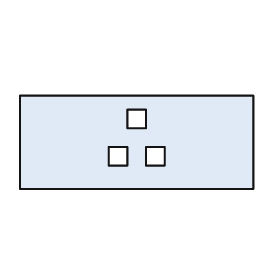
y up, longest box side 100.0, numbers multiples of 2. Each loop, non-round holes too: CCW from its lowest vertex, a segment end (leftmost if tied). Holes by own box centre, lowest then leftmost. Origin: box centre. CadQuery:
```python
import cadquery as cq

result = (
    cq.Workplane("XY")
    .moveTo(-50.0, -20.0)
    .lineTo(50.0, -20.0)
    .lineTo(50.0, 20.0)
    .lineTo(-50.0, 20.0)
    .close()
    .moveTo(-12.0, -10.0)
    .lineTo(-4.0, -10.0)
    .lineTo(-4.0, -2.0)
    .lineTo(-12.0, -2.0)
    .close()
    .moveTo(4.0, -10.0)
    .lineTo(12.0, -10.0)
    .lineTo(12.0, -2.0)
    .lineTo(4.0, -2.0)
    .close()
    .moveTo(-4.0, 6.0)
    .lineTo(4.0, 6.0)
    .lineTo(4.0, 14.0)
    .lineTo(-4.0, 14.0)
    .close()
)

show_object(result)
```